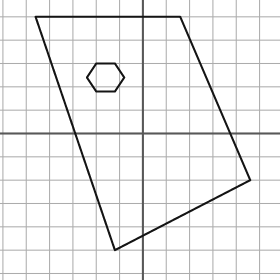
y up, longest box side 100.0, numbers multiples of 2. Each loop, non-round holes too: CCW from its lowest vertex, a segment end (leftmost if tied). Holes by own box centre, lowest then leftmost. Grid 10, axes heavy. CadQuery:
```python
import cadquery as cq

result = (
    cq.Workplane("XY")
    .moveTo(-12.0, -50.0)
    .lineTo(46.0, -20.0)
    .lineTo(16.0, 50.0)
    .lineTo(-46.0, 50.0)
    .close()
    .moveTo(-20.0, 18.0)
    .lineTo(-12.0, 18.0)
    .lineTo(-8.0, 24.0)
    .lineTo(-12.0, 30.0)
    .lineTo(-20.0, 30.0)
    .lineTo(-24.0, 24.0)
    .close()
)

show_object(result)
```